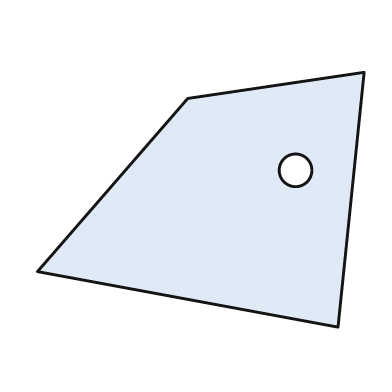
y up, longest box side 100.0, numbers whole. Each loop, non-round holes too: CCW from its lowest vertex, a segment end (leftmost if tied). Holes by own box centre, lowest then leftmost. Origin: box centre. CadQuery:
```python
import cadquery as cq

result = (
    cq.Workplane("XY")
    .moveTo(42.0, -39.0)
    .lineTo(50.0, 39.0)
    .lineTo(-4.0, 31.0)
    .lineTo(-50.0, -22.0)
    .close()
    .moveTo(29.0, 9.0)
    .circle(5.0)
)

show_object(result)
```